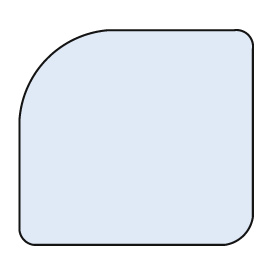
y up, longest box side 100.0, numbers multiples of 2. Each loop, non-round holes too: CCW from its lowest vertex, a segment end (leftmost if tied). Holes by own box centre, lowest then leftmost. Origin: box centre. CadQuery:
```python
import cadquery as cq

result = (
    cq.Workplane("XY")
    .moveTo(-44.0, -46.0)
    .lineTo(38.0, -46.0)
    .threePointArc((46.0, -42.0), (50.0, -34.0))
    .lineTo(50.0, 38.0)
    .threePointArc((48.0, 44.0), (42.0, 46.0))
    .lineTo(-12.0, 46.0)
    .threePointArc((-38.0, 34.0), (-50.0, 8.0))
    .lineTo(-50.0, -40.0)
    .threePointArc((-48.0, -44.0), (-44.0, -46.0))
    .close()
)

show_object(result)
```